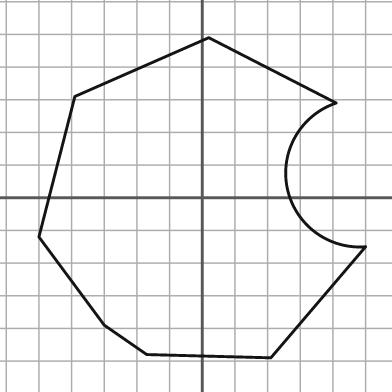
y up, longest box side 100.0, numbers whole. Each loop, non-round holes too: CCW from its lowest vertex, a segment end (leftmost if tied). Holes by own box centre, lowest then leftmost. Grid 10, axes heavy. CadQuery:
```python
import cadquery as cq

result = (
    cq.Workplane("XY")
    .moveTo(21.0, -49.0)
    .lineTo(50.0, -15.0)
    .threePointArc((26.0, 3.0), (41.0, 29.0))
    .lineTo(2.0, 49.0)
    .lineTo(-39.0, 31.0)
    .lineTo(-50.0, -12.0)
    .lineTo(-30.0, -39.0)
    .lineTo(-17.0, -48.0)
    .close()
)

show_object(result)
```